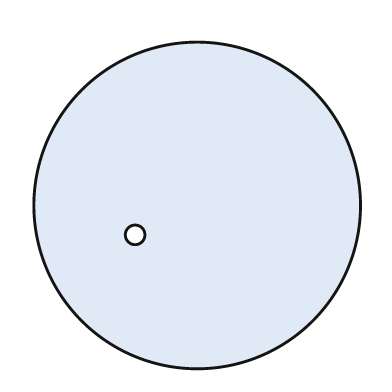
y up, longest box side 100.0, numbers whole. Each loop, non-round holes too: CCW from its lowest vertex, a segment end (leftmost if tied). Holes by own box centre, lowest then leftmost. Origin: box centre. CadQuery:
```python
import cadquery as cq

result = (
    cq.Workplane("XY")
    .moveTo(0.0, 0.0)
    .circle(50.0)
    .moveTo(-19.0, -9.0)
    .circle(3.0)
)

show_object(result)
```